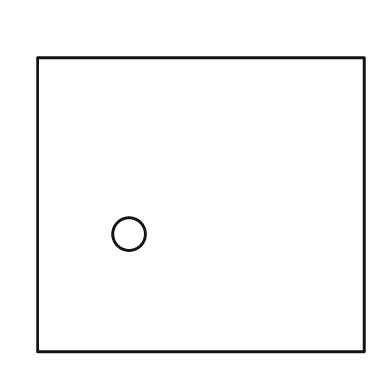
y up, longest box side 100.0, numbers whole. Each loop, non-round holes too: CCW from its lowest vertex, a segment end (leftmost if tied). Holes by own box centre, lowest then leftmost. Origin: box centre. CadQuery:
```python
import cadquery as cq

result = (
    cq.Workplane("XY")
    .moveTo(-50.0, -45.0)
    .lineTo(50.0, -45.0)
    .lineTo(50.0, 45.0)
    .lineTo(-50.0, 45.0)
    .close()
    .moveTo(-22.0, -9.0)
    .circle(5.0)
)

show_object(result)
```